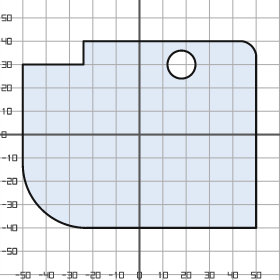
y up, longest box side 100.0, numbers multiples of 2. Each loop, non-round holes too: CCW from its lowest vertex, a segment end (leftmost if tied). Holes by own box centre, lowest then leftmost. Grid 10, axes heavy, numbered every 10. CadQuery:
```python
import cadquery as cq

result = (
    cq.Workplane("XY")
    .moveTo(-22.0, -40.0)
    .lineTo(50.0, -40.0)
    .lineTo(50.0, 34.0)
    .threePointArc((48.0, 38.0), (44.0, 40.0))
    .lineTo(-24.0, 40.0)
    .lineTo(-24.0, 30.0)
    .lineTo(-50.0, 30.0)
    .lineTo(-50.0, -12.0)
    .threePointArc((-42.0, -32.0), (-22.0, -40.0))
    .close()
    .moveTo(18.0, 30.0)
    .circle(6.0)
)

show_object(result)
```